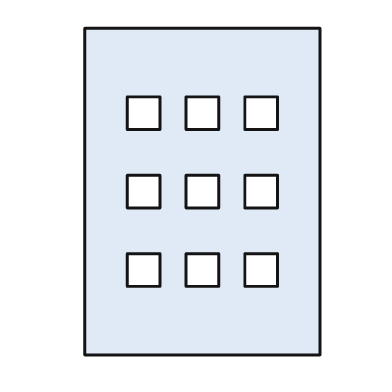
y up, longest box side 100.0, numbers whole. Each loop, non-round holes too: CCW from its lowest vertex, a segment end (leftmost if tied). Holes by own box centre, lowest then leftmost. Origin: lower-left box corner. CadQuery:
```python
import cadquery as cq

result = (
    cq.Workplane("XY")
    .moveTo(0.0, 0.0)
    .lineTo(72.0, 0.0)
    .lineTo(72.0, 100.0)
    .lineTo(0.0, 100.0)
    .close()
    .moveTo(13.0, 21.0)
    .lineTo(23.0, 21.0)
    .lineTo(23.0, 31.0)
    .lineTo(13.0, 31.0)
    .close()
    .moveTo(31.0, 21.0)
    .lineTo(41.0, 21.0)
    .lineTo(41.0, 31.0)
    .lineTo(31.0, 31.0)
    .close()
    .moveTo(49.0, 21.0)
    .lineTo(59.0, 21.0)
    .lineTo(59.0, 31.0)
    .lineTo(49.0, 31.0)
    .close()
    .moveTo(13.0, 45.0)
    .lineTo(23.0, 45.0)
    .lineTo(23.0, 55.0)
    .lineTo(13.0, 55.0)
    .close()
    .moveTo(31.0, 45.0)
    .lineTo(41.0, 45.0)
    .lineTo(41.0, 55.0)
    .lineTo(31.0, 55.0)
    .close()
    .moveTo(49.0, 45.0)
    .lineTo(59.0, 45.0)
    .lineTo(59.0, 55.0)
    .lineTo(49.0, 55.0)
    .close()
    .moveTo(13.0, 69.0)
    .lineTo(23.0, 69.0)
    .lineTo(23.0, 79.0)
    .lineTo(13.0, 79.0)
    .close()
    .moveTo(31.0, 69.0)
    .lineTo(41.0, 69.0)
    .lineTo(41.0, 79.0)
    .lineTo(31.0, 79.0)
    .close()
    .moveTo(49.0, 69.0)
    .lineTo(59.0, 69.0)
    .lineTo(59.0, 79.0)
    .lineTo(49.0, 79.0)
    .close()
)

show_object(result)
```